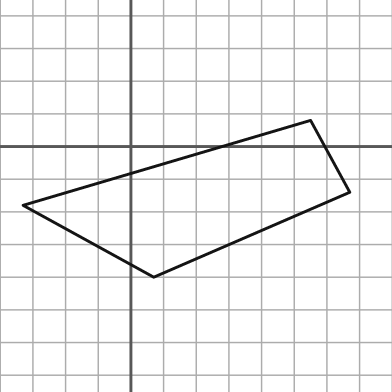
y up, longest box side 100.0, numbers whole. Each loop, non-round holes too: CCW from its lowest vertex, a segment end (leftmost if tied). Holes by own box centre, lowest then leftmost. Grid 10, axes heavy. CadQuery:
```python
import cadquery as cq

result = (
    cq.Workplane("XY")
    .moveTo(7.0, -40.0)
    .lineTo(67.0, -14.0)
    .lineTo(55.0, 8.0)
    .lineTo(-33.0, -18.0)
    .close()
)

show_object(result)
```